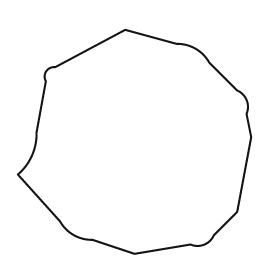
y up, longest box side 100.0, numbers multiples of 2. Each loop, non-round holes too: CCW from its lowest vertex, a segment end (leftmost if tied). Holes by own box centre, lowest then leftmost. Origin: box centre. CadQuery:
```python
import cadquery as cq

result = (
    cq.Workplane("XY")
    .moveTo(0.0, -48.0)
    .lineTo(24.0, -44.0)
    .threePointArc((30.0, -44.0), (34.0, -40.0))
    .lineTo(44.0, -30.0)
    .lineTo(50.0, 2.0)
    .lineTo(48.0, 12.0)
    .threePointArc((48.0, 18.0), (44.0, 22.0))
    .lineTo(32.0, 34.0)
    .threePointArc((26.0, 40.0), (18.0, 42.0))
    .lineTo(-4.0, 48.0)
    .lineTo(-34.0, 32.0)
    .threePointArc((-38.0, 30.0), (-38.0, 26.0))
    .lineTo(-42.0, 4.0)
    .threePointArc((-44.0, -6.0), (-50.0, -14.0))
    .lineTo(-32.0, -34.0)
    .threePointArc((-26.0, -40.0), (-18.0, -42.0))
    .close()
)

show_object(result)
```